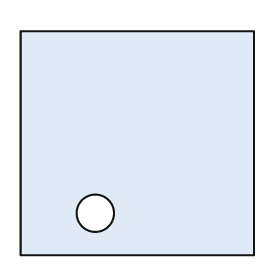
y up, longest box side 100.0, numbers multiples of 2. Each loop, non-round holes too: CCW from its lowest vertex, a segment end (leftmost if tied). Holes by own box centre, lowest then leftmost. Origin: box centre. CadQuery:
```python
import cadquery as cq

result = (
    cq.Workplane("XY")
    .moveTo(-50.0, -48.0)
    .lineTo(50.0, -48.0)
    .lineTo(50.0, 48.0)
    .lineTo(-50.0, 48.0)
    .close()
    .moveTo(-18.0, -30.0)
    .circle(8.0)
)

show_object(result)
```